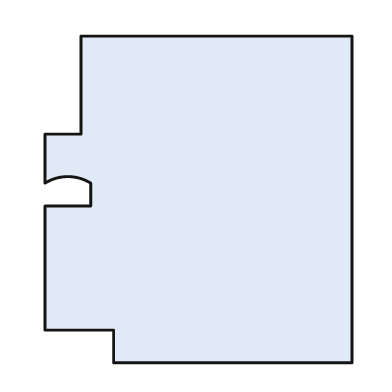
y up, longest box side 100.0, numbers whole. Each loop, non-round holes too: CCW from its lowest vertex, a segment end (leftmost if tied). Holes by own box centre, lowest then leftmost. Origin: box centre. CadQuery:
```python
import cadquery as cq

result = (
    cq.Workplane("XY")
    .moveTo(-26.0, -50.0)
    .lineTo(47.0, -50.0)
    .lineTo(47.0, 50.0)
    .lineTo(-36.0, 50.0)
    .lineTo(-36.0, 20.0)
    .lineTo(-47.0, 20.0)
    .lineTo(-47.0, 5.0)
    .threePointArc((-40.0, 7.0), (-33.0, 5.0))
    .lineTo(-33.0, -2.0)
    .lineTo(-47.0, -2.0)
    .lineTo(-47.0, -40.0)
    .lineTo(-26.0, -40.0)
    .close()
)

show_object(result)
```